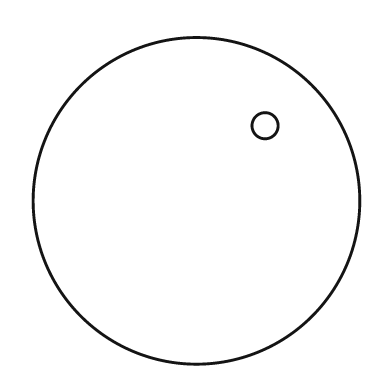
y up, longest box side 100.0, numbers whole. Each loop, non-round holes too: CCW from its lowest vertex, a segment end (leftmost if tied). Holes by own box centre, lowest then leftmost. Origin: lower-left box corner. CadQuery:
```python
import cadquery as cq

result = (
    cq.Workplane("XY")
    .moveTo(50.0, 50.0)
    .circle(50.0)
    .moveTo(71.0, 73.0)
    .circle(4.0)
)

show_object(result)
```